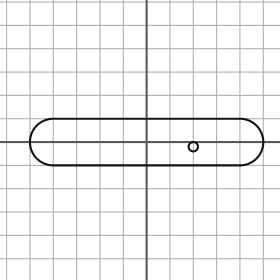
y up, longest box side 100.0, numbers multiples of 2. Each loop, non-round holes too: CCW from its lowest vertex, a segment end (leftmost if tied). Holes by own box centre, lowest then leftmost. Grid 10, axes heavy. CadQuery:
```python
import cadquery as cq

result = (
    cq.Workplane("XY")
    .moveTo(-40.0, -10.0)
    .lineTo(40.0, -10.0)
    .threePointArc((50.0, 0.0), (40.0, 10.0))
    .lineTo(-40.0, 10.0)
    .threePointArc((-50.0, 0.0), (-40.0, -10.0))
    .close()
    .moveTo(20.0, -2.0)
    .circle(2.0)
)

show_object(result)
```